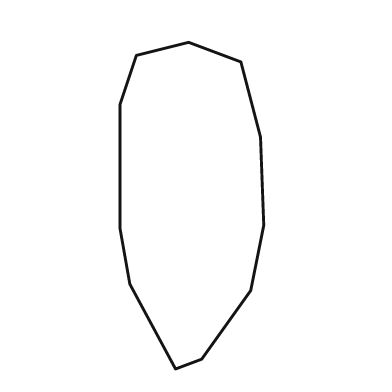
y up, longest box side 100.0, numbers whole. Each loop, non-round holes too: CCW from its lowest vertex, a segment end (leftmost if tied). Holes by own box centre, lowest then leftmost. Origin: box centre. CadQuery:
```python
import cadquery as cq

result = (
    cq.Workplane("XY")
    .moveTo(-5.0, -50.0)
    .lineTo(3.0, -47.0)
    .lineTo(18.0, -26.0)
    .lineTo(22.0, -6.0)
    .lineTo(21.0, 21.0)
    .lineTo(15.0, 44.0)
    .lineTo(-1.0, 50.0)
    .lineTo(-17.0, 46.0)
    .lineTo(-22.0, 31.0)
    .lineTo(-22.0, -7.0)
    .lineTo(-19.0, -24.0)
    .close()
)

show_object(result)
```